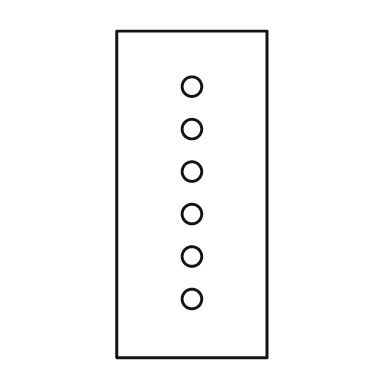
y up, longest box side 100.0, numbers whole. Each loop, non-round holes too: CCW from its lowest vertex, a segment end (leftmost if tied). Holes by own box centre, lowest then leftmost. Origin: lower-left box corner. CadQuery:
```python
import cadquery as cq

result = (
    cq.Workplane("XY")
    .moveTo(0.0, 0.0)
    .lineTo(46.0, 0.0)
    .lineTo(46.0, 100.0)
    .lineTo(0.0, 100.0)
    .close()
    .moveTo(23.0, 18.0)
    .circle(3.0)
    .moveTo(23.0, 31.0)
    .circle(3.0)
    .moveTo(23.0, 44.0)
    .circle(3.0)
    .moveTo(23.0, 57.0)
    .circle(3.0)
    .moveTo(23.0, 70.0)
    .circle(3.0)
    .moveTo(23.0, 83.0)
    .circle(3.0)
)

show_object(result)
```